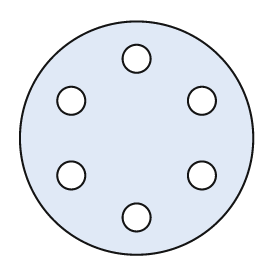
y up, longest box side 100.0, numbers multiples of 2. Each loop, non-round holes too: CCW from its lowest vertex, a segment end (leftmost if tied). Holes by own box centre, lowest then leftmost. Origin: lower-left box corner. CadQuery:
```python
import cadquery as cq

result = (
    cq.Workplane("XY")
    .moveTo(50.0, 50.0)
    .circle(50.0)
    .moveTo(50.0, 16.0)
    .circle(6.0)
    .moveTo(22.0, 34.0)
    .circle(6.0)
    .moveTo(78.0, 34.0)
    .circle(6.0)
    .moveTo(22.0, 66.0)
    .circle(6.0)
    .moveTo(78.0, 66.0)
    .circle(6.0)
    .moveTo(50.0, 84.0)
    .circle(6.0)
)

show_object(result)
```